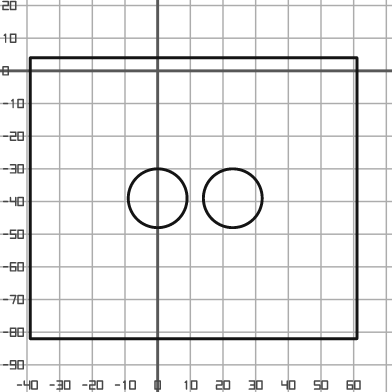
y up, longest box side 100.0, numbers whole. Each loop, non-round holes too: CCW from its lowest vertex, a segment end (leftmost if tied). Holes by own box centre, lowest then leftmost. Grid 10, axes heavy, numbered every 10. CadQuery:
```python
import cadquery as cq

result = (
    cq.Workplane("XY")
    .moveTo(-39.0, -82.0)
    .lineTo(61.0, -82.0)
    .lineTo(61.0, 4.0)
    .lineTo(-39.0, 4.0)
    .close()
    .moveTo(0.0, -39.0)
    .circle(9.0)
    .moveTo(23.0, -39.0)
    .circle(9.0)
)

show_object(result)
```